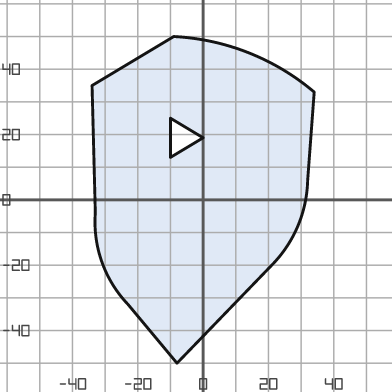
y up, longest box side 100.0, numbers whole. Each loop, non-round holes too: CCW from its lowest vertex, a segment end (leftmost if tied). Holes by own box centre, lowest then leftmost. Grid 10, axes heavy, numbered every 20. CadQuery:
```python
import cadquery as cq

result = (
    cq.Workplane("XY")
    .moveTo(-8.0, -50.0)
    .lineTo(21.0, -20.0)
    .threePointArc((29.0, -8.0), (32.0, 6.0))
    .lineTo(34.0, 33.0)
    .threePointArc((14.0, 45.0), (-9.0, 50.0))
    .lineTo(-34.0, 35.0)
    .lineTo(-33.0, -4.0)
    .threePointArc((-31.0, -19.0), (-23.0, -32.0))
    .close()
    .moveTo(-10.0, 13.0)
    .lineTo(0.0, 19.0)
    .lineTo(-10.0, 25.0)
    .close()
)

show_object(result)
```